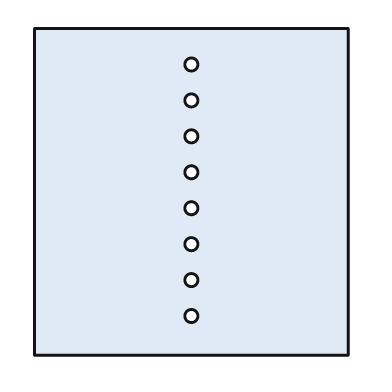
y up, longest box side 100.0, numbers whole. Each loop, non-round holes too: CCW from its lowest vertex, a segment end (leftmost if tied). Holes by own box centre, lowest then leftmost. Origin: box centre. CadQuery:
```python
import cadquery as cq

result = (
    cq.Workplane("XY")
    .moveTo(-48.0, -50.0)
    .lineTo(48.0, -50.0)
    .lineTo(48.0, 50.0)
    .lineTo(-48.0, 50.0)
    .close()
    .moveTo(0.0, -38.0)
    .circle(2.0)
    .moveTo(0.0, -27.0)
    .circle(2.0)
    .moveTo(0.0, -16.0)
    .circle(2.0)
    .moveTo(0.0, -5.0)
    .circle(2.0)
    .moveTo(0.0, 6.0)
    .circle(2.0)
    .moveTo(0.0, 17.0)
    .circle(2.0)
    .moveTo(0.0, 28.0)
    .circle(2.0)
    .moveTo(0.0, 39.0)
    .circle(2.0)
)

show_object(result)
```